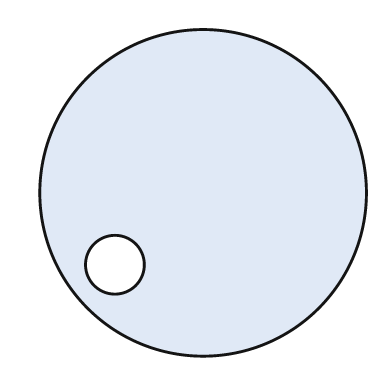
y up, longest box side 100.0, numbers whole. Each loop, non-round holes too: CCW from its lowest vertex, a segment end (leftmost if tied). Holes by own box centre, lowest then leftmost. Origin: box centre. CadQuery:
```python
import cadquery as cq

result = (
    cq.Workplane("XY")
    .moveTo(0.0, 0.0)
    .circle(50.0)
    .moveTo(-27.0, -22.0)
    .circle(9.0)
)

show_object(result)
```